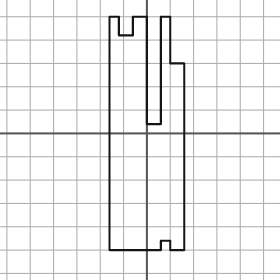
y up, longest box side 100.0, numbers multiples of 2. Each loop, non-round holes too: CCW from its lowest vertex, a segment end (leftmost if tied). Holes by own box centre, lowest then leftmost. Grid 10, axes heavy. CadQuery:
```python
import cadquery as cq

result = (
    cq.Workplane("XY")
    .moveTo(-16.0, -50.0)
    .lineTo(6.0, -50.0)
    .lineTo(6.0, -46.0)
    .lineTo(10.0, -46.0)
    .lineTo(10.0, -50.0)
    .lineTo(16.0, -50.0)
    .lineTo(16.0, 30.0)
    .lineTo(10.0, 30.0)
    .lineTo(10.0, 50.0)
    .lineTo(6.0, 50.0)
    .lineTo(6.0, 4.0)
    .lineTo(0.0, 4.0)
    .lineTo(0.0, 50.0)
    .lineTo(-6.0, 50.0)
    .lineTo(-6.0, 42.0)
    .lineTo(-12.0, 42.0)
    .lineTo(-12.0, 50.0)
    .lineTo(-16.0, 50.0)
    .close()
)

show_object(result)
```